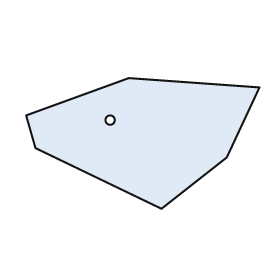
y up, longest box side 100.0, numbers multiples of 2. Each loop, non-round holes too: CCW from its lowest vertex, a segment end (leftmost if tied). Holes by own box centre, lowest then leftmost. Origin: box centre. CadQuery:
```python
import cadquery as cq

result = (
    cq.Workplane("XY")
    .moveTo(8.0, -28.0)
    .lineTo(36.0, -6.0)
    .lineTo(50.0, 24.0)
    .lineTo(-6.0, 28.0)
    .lineTo(-50.0, 12.0)
    .lineTo(-46.0, -2.0)
    .close()
    .moveTo(-14.0, 10.0)
    .circle(2.0)
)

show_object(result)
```